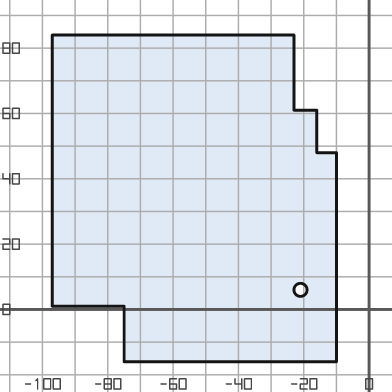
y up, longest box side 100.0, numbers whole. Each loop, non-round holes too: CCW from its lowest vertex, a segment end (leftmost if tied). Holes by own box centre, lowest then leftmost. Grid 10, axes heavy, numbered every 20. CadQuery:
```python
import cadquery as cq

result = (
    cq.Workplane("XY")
    .moveTo(-75.0, -16.0)
    .lineTo(-10.0, -16.0)
    .lineTo(-10.0, 48.0)
    .lineTo(-16.0, 48.0)
    .lineTo(-16.0, 61.0)
    .lineTo(-23.0, 61.0)
    .lineTo(-23.0, 84.0)
    .lineTo(-97.0, 84.0)
    .lineTo(-97.0, 1.0)
    .lineTo(-75.0, 1.0)
    .close()
    .moveTo(-21.0, 6.0)
    .circle(2.0)
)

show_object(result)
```